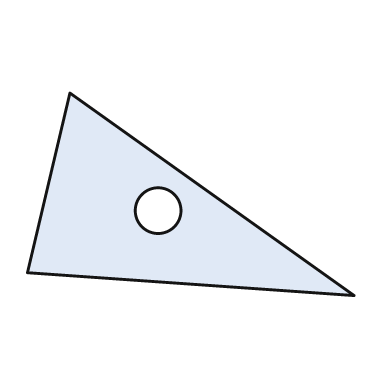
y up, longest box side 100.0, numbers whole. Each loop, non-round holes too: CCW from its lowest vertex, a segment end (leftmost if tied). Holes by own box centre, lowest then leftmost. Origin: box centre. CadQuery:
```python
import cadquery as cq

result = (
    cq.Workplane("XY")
    .moveTo(50.0, -31.0)
    .lineTo(-37.0, 31.0)
    .lineTo(-50.0, -24.0)
    .close()
    .moveTo(-10.0, -5.0)
    .circle(7.0)
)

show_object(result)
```